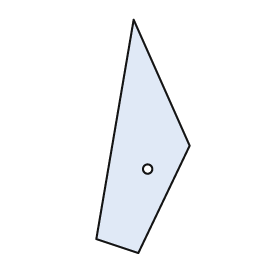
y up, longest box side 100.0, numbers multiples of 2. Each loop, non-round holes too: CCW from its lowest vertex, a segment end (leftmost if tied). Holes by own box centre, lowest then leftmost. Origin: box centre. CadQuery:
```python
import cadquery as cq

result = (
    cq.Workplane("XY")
    .moveTo(-2.0, -50.0)
    .lineTo(20.0, -4.0)
    .lineTo(-4.0, 50.0)
    .lineTo(-20.0, -44.0)
    .close()
    .moveTo(2.0, -14.0)
    .circle(2.0)
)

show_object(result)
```